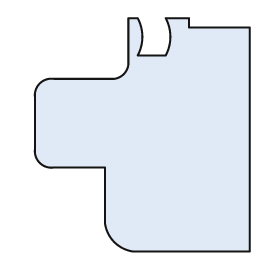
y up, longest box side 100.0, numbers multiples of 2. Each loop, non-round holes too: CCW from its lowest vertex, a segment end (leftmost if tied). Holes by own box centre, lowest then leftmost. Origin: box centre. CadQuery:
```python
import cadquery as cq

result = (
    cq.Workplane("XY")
    .moveTo(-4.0, -50.0)
    .lineTo(46.0, -50.0)
    .lineTo(46.0, 46.0)
    .lineTo(20.0, 46.0)
    .lineTo(20.0, 50.0)
    .lineTo(10.0, 50.0)
    .threePointArc((12.0, 42.0), (10.0, 34.0))
    .lineTo(-2.0, 34.0)
    .threePointArc((0.0, 42.0), (-2.0, 50.0))
    .lineTo(-6.0, 50.0)
    .lineTo(-6.0, 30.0)
    .threePointArc((-8.0, 26.0), (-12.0, 24.0))
    .lineTo(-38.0, 24.0)
    .threePointArc((-44.0, 22.0), (-46.0, 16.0))
    .lineTo(-46.0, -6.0)
    .threePointArc((-44.0, -12.0), (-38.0, -14.0))
    .lineTo(-16.0, -14.0)
    .lineTo(-16.0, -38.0)
    .threePointArc((-12.0, -46.0), (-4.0, -50.0))
    .close()
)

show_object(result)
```